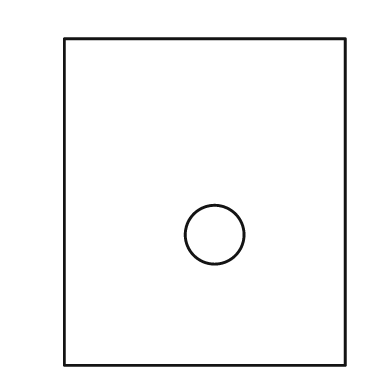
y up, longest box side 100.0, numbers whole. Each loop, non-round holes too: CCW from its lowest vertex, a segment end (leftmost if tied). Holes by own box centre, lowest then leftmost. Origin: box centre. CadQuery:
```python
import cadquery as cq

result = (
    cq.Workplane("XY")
    .moveTo(-43.0, -50.0)
    .lineTo(43.0, -50.0)
    .lineTo(43.0, 50.0)
    .lineTo(-43.0, 50.0)
    .close()
    .moveTo(3.0, -10.0)
    .circle(9.0)
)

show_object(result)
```